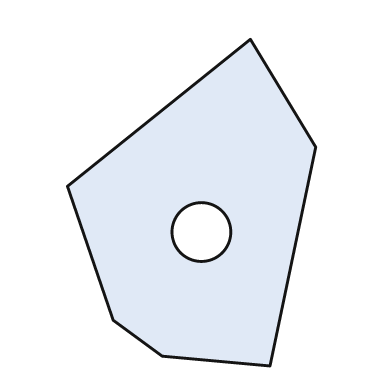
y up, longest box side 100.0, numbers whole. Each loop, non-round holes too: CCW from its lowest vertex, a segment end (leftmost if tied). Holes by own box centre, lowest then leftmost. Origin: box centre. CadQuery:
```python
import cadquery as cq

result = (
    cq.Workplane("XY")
    .moveTo(24.0, -50.0)
    .lineTo(38.0, 17.0)
    .lineTo(18.0, 50.0)
    .lineTo(-38.0, 5.0)
    .lineTo(-24.0, -36.0)
    .lineTo(-9.0, -47.0)
    .close()
    .moveTo(3.0, -9.0)
    .circle(9.0)
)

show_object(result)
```